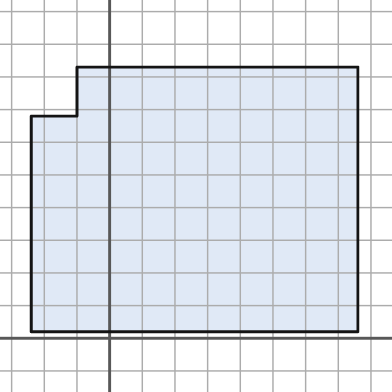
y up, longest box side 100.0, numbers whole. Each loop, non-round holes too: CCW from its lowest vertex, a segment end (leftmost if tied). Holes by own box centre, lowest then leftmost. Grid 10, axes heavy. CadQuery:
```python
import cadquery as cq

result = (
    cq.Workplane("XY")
    .moveTo(-24.0, 2.0)
    .lineTo(76.0, 2.0)
    .lineTo(76.0, 83.0)
    .lineTo(-10.0, 83.0)
    .lineTo(-10.0, 68.0)
    .lineTo(-24.0, 68.0)
    .close()
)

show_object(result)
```